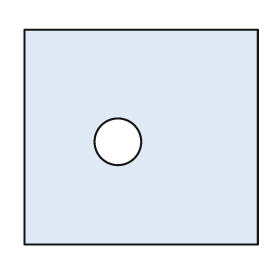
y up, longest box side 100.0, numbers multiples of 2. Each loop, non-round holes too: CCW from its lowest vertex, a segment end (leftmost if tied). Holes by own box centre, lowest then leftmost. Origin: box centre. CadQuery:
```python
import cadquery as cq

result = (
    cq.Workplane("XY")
    .moveTo(-50.0, -46.0)
    .lineTo(50.0, -46.0)
    .lineTo(50.0, 46.0)
    .lineTo(-50.0, 46.0)
    .close()
    .moveTo(-10.0, -2.0)
    .circle(10.0)
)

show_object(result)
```